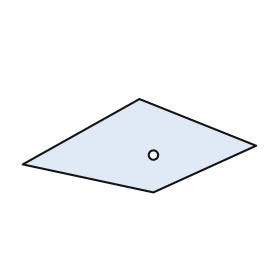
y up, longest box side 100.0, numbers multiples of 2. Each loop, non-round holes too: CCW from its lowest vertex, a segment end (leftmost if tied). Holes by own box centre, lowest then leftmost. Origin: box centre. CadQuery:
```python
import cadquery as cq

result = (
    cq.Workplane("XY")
    .moveTo(6.0, -20.0)
    .lineTo(50.0, 0.0)
    .lineTo(0.0, 20.0)
    .lineTo(-50.0, -8.0)
    .close()
    .moveTo(6.0, -4.0)
    .circle(2.0)
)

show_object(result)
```